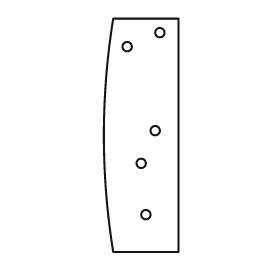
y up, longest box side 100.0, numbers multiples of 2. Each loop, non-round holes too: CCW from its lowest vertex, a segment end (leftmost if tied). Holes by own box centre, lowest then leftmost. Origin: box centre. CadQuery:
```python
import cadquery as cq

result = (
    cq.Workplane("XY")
    .moveTo(-12.0, -50.0)
    .lineTo(16.0, -50.0)
    .lineTo(16.0, 50.0)
    .lineTo(-12.0, 50.0)
    .threePointArc((-16.0, 0.0), (-12.0, -50.0))
    .close()
    .moveTo(2.0, -34.0)
    .circle(2.0)
    .moveTo(0.0, -12.0)
    .circle(2.0)
    .moveTo(6.0, 2.0)
    .circle(2.0)
    .moveTo(-6.0, 38.0)
    .circle(2.0)
    .moveTo(8.0, 44.0)
    .circle(2.0)
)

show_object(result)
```